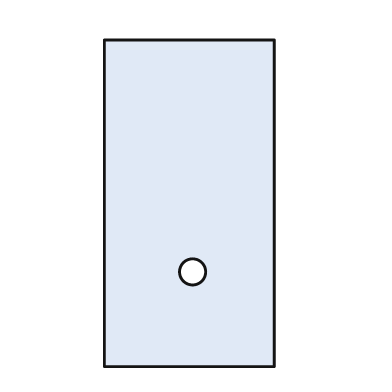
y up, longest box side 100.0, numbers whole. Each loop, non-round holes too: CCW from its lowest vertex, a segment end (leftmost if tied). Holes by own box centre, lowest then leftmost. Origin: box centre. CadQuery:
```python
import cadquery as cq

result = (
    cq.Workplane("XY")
    .moveTo(-26.0, -50.0)
    .lineTo(26.0, -50.0)
    .lineTo(26.0, 50.0)
    .lineTo(-26.0, 50.0)
    .close()
    .moveTo(1.0, -21.0)
    .circle(4.0)
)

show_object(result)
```